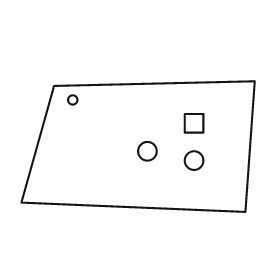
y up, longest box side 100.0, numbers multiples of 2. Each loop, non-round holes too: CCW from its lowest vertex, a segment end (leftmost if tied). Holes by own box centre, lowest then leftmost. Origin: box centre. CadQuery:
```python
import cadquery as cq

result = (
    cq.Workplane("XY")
    .moveTo(46.0, -28.0)
    .lineTo(50.0, 28.0)
    .lineTo(-36.0, 26.0)
    .lineTo(-50.0, -24.0)
    .close()
    .moveTo(24.0, -6.0)
    .circle(4.0)
    .moveTo(4.0, -2.0)
    .circle(4.0)
    .moveTo(20.0, 6.0)
    .lineTo(28.0, 6.0)
    .lineTo(28.0, 14.0)
    .lineTo(20.0, 14.0)
    .close()
    .moveTo(-28.0, 20.0)
    .circle(2.0)
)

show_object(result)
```